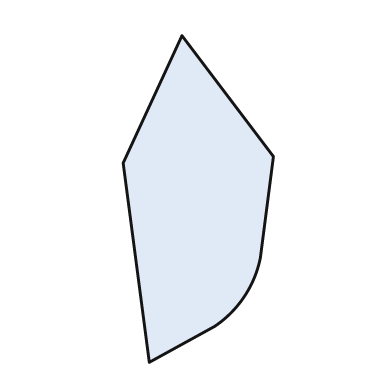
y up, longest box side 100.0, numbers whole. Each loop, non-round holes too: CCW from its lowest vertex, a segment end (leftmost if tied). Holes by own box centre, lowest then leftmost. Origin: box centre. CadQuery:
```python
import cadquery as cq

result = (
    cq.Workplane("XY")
    .moveTo(-15.0, -50.0)
    .lineTo(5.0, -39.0)
    .threePointArc((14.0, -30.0), (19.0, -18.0))
    .lineTo(23.0, 13.0)
    .lineTo(-5.0, 50.0)
    .lineTo(-23.0, 11.0)
    .close()
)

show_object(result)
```